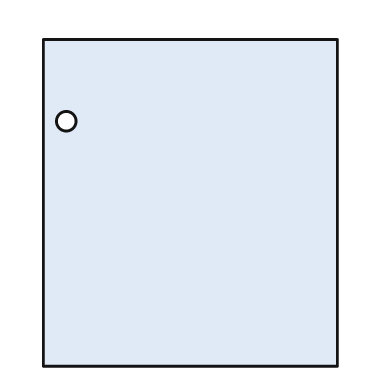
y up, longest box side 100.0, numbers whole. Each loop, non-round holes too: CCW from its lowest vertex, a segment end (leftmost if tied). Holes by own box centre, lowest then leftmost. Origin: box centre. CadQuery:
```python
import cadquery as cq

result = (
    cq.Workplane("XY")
    .moveTo(-45.0, -50.0)
    .lineTo(45.0, -50.0)
    .lineTo(45.0, 50.0)
    .lineTo(-45.0, 50.0)
    .close()
    .moveTo(-38.0, 25.0)
    .circle(3.0)
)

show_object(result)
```